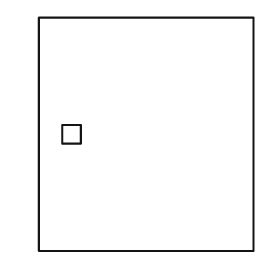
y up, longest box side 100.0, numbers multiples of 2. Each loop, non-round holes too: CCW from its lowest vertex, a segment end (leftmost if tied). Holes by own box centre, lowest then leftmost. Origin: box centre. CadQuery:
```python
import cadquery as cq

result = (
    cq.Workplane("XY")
    .moveTo(-46.0, -50.0)
    .lineTo(46.0, -50.0)
    .lineTo(46.0, 50.0)
    .lineTo(-46.0, 50.0)
    .close()
    .moveTo(-36.0, -4.0)
    .lineTo(-28.0, -4.0)
    .lineTo(-28.0, 4.0)
    .lineTo(-36.0, 4.0)
    .close()
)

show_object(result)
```